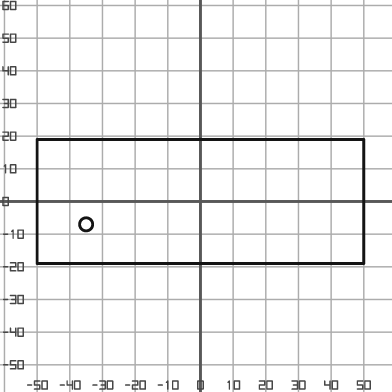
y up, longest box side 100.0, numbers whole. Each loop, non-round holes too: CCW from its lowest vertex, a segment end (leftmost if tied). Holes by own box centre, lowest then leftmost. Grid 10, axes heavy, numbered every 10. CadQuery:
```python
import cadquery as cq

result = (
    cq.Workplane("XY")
    .moveTo(-50.0, -19.0)
    .lineTo(50.0, -19.0)
    .lineTo(50.0, 19.0)
    .lineTo(-50.0, 19.0)
    .close()
    .moveTo(-35.0, -7.0)
    .circle(2.0)
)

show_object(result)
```